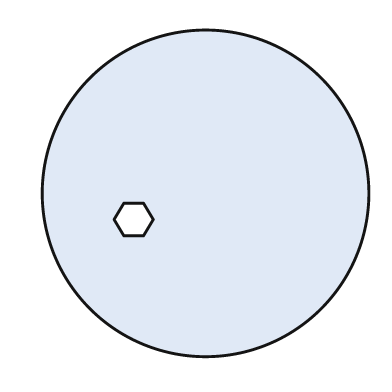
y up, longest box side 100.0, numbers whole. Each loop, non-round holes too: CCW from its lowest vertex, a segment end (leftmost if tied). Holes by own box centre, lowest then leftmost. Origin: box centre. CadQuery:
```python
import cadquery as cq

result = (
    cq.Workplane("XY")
    .moveTo(0.0, 0.0)
    .circle(50.0)
    .moveTo(-25.0, -13.0)
    .lineTo(-19.0, -13.0)
    .lineTo(-16.0, -8.0)
    .lineTo(-19.0, -3.0)
    .lineTo(-25.0, -3.0)
    .lineTo(-28.0, -8.0)
    .close()
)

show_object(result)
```